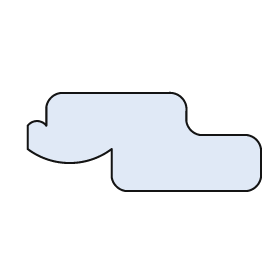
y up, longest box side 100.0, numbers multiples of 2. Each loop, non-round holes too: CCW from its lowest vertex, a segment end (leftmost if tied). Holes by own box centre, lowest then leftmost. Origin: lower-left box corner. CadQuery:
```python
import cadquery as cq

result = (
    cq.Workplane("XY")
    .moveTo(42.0, 0.0)
    .lineTo(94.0, 0.0)
    .threePointArc((98.0, 2.0), (100.0, 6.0))
    .lineTo(100.0, 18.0)
    .threePointArc((98.0, 22.0), (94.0, 24.0))
    .lineTo(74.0, 24.0)
    .threePointArc((70.0, 26.0), (68.0, 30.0))
    .lineTo(68.0, 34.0)
    .threePointArc((66.0, 40.0), (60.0, 42.0))
    .lineTo(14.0, 42.0)
    .threePointArc((10.0, 40.0), (8.0, 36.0))
    .lineTo(8.0, 28.0)
    .threePointArc((4.0, 30.0), (0.0, 28.0))
    .lineTo(0.0, 18.0)
    .threePointArc((18.0, 12.0), (36.0, 18.0))
    .lineTo(36.0, 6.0)
    .threePointArc((38.0, 2.0), (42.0, 0.0))
    .close()
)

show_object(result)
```